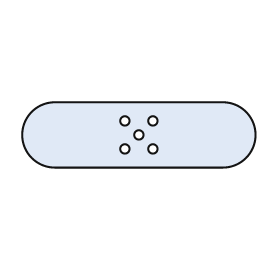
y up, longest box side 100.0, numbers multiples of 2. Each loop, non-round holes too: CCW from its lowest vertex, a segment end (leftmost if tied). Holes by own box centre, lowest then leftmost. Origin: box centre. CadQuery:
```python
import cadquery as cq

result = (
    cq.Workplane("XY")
    .moveTo(-36.0, -14.0)
    .lineTo(36.0, -14.0)
    .threePointArc((50.0, 0.0), (36.0, 14.0))
    .lineTo(-36.0, 14.0)
    .threePointArc((-50.0, 0.0), (-36.0, -14.0))
    .close()
    .moveTo(-6.0, -6.0)
    .circle(2.0)
    .moveTo(6.0, -6.0)
    .circle(2.0)
    .moveTo(0.0, 0.0)
    .circle(2.0)
    .moveTo(-6.0, 6.0)
    .circle(2.0)
    .moveTo(6.0, 6.0)
    .circle(2.0)
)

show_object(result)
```